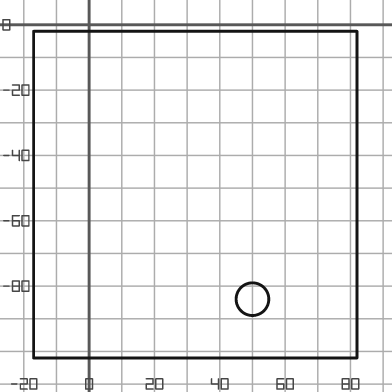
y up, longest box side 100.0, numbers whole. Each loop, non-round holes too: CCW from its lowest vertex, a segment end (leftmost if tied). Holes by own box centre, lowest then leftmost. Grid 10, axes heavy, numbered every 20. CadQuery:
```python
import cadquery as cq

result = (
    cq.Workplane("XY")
    .moveTo(-17.0, -102.0)
    .lineTo(82.0, -102.0)
    .lineTo(82.0, -2.0)
    .lineTo(-17.0, -2.0)
    .close()
    .moveTo(50.0, -84.0)
    .circle(5.0)
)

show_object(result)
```